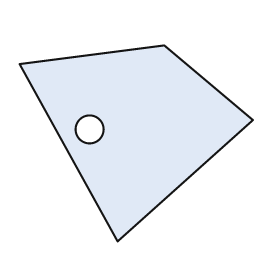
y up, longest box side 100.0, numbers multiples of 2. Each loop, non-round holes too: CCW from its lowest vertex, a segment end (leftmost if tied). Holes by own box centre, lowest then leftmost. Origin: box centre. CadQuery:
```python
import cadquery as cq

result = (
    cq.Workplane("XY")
    .moveTo(-8.0, -42.0)
    .lineTo(50.0, 10.0)
    .lineTo(12.0, 42.0)
    .lineTo(-50.0, 34.0)
    .close()
    .moveTo(-20.0, 6.0)
    .circle(6.0)
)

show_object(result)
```